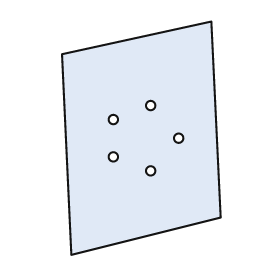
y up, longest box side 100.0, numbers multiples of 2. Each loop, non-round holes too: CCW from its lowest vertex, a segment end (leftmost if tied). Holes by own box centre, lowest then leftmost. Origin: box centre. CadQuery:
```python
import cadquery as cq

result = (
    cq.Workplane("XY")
    .moveTo(-30.0, -50.0)
    .lineTo(34.0, -34.0)
    .lineTo(30.0, 50.0)
    .lineTo(-34.0, 36.0)
    .close()
    .moveTo(4.0, -14.0)
    .circle(2.0)
    .moveTo(-12.0, -8.0)
    .circle(2.0)
    .moveTo(16.0, 0.0)
    .circle(2.0)
    .moveTo(-12.0, 8.0)
    .circle(2.0)
    .moveTo(4.0, 14.0)
    .circle(2.0)
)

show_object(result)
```